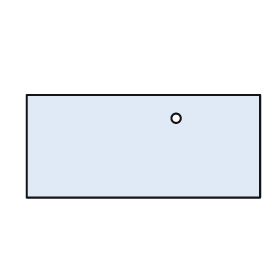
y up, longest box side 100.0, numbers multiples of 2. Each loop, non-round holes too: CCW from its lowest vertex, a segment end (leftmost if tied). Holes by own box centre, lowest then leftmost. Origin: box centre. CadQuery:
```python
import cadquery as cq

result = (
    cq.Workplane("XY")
    .moveTo(-50.0, -22.0)
    .lineTo(50.0, -22.0)
    .lineTo(50.0, 22.0)
    .lineTo(-50.0, 22.0)
    .close()
    .moveTo(14.0, 12.0)
    .circle(2.0)
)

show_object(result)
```